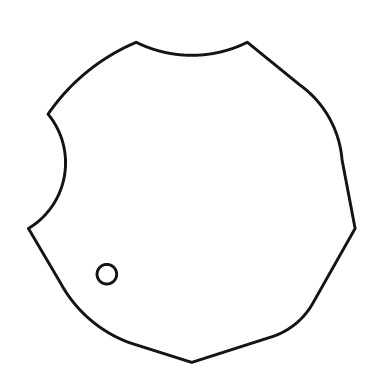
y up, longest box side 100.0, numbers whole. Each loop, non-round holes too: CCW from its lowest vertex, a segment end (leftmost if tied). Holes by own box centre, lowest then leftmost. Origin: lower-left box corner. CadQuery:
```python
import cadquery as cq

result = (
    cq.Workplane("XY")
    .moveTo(50.0, 0.0)
    .lineTo(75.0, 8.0)
    .threePointArc((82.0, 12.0), (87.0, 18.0))
    .lineTo(100.0, 41.0)
    .lineTo(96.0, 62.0)
    .threePointArc((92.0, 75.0), (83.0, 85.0))
    .lineTo(67.0, 98.0)
    .threePointArc((50.0, 94.0), (33.0, 98.0))
    .threePointArc((18.0, 89.0), (6.0, 76.0))
    .threePointArc((11.0, 57.0), (0.0, 41.0))
    .lineTo(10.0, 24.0)
    .threePointArc((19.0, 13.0), (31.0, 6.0))
    .close()
    .moveTo(24.0, 27.0)
    .circle(3.0)
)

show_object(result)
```